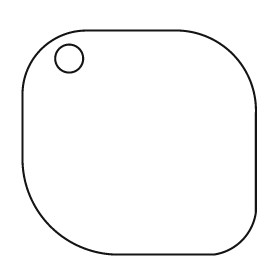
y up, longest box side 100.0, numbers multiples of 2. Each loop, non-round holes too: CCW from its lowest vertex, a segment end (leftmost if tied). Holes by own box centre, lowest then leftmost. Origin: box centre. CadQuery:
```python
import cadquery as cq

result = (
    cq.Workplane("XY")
    .moveTo(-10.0, -48.0)
    .lineTo(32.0, -48.0)
    .threePointArc((44.0, -42.0), (50.0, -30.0))
    .lineTo(50.0, 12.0)
    .threePointArc((40.0, 38.0), (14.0, 48.0))
    .lineTo(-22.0, 48.0)
    .threePointArc((-42.0, 40.0), (-50.0, 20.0))
    .lineTo(-50.0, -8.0)
    .threePointArc((-38.0, -36.0), (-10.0, -48.0))
    .close()
    .moveTo(-30.0, 36.0)
    .circle(6.0)
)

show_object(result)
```